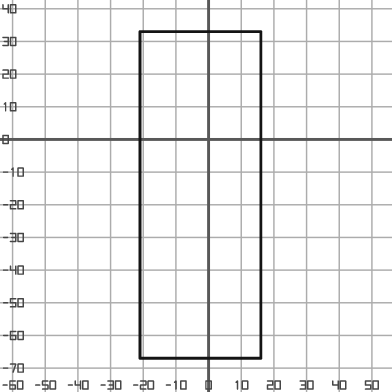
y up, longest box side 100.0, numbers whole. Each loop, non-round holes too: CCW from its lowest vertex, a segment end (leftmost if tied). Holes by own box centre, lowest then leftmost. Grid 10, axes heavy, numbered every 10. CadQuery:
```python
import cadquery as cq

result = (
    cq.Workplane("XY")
    .moveTo(-21.0, -67.0)
    .lineTo(16.0, -67.0)
    .lineTo(16.0, 33.0)
    .lineTo(-21.0, 33.0)
    .close()
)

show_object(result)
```